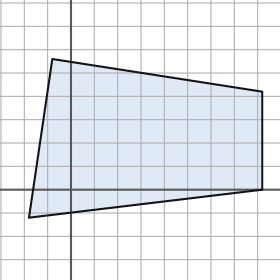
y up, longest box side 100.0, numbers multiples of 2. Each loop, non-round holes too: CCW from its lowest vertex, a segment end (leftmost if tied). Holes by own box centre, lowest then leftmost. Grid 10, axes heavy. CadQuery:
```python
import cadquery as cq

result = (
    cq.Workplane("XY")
    .moveTo(-18.0, -12.0)
    .lineTo(82.0, 0.0)
    .lineTo(82.0, 42.0)
    .lineTo(-8.0, 56.0)
    .close()
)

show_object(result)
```